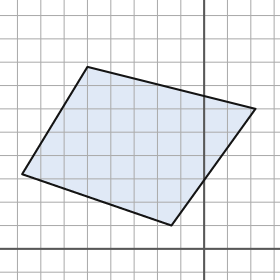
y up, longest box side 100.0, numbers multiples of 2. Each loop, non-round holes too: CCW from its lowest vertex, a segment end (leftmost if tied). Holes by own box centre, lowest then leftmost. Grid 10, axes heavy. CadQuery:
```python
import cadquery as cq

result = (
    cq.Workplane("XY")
    .moveTo(-14.0, 10.0)
    .lineTo(22.0, 60.0)
    .lineTo(-50.0, 78.0)
    .lineTo(-78.0, 32.0)
    .close()
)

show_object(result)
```